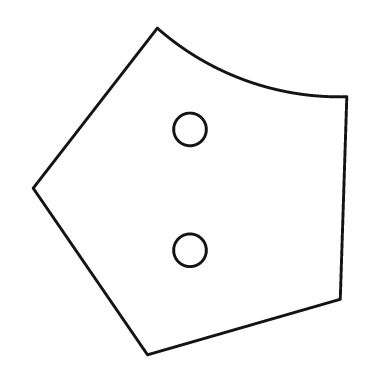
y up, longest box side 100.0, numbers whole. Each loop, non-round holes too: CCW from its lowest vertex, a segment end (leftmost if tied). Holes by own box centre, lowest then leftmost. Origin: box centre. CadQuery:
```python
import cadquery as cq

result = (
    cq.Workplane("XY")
    .moveTo(-13.0, -50.0)
    .lineTo(46.0, -33.0)
    .lineTo(48.0, 29.0)
    .threePointArc((17.0, 34.0), (-10.0, 50.0))
    .lineTo(-48.0, 1.0)
    .close()
    .moveTo(0.0, -18.0)
    .circle(5.0)
    .moveTo(0.0, 19.0)
    .circle(5.0)
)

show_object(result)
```